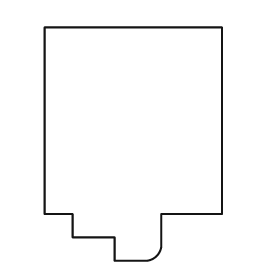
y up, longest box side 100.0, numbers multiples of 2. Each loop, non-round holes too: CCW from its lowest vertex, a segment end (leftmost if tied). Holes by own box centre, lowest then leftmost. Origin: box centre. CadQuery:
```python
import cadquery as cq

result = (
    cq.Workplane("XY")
    .moveTo(-8.0, -50.0)
    .lineTo(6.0, -50.0)
    .threePointArc((10.0, -48.0), (12.0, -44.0))
    .lineTo(12.0, -30.0)
    .lineTo(38.0, -30.0)
    .lineTo(38.0, 50.0)
    .lineTo(-38.0, 50.0)
    .lineTo(-38.0, -30.0)
    .lineTo(-26.0, -30.0)
    .lineTo(-26.0, -40.0)
    .lineTo(-8.0, -40.0)
    .close()
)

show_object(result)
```